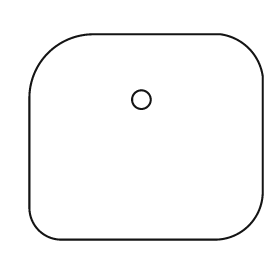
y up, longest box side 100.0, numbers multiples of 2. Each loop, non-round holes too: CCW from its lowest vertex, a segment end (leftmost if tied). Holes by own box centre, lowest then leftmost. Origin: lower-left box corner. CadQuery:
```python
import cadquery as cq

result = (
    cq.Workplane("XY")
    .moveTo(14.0, 0.0)
    .lineTo(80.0, 0.0)
    .threePointArc((94.0, 6.0), (100.0, 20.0))
    .lineTo(100.0, 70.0)
    .threePointArc((94.0, 82.0), (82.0, 88.0))
    .lineTo(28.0, 88.0)
    .threePointArc((8.0, 80.0), (0.0, 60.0))
    .lineTo(0.0, 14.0)
    .threePointArc((4.0, 4.0), (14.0, 0.0))
    .close()
    .moveTo(48.0, 60.0)
    .circle(4.0)
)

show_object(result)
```